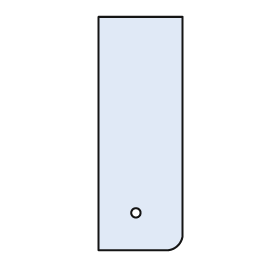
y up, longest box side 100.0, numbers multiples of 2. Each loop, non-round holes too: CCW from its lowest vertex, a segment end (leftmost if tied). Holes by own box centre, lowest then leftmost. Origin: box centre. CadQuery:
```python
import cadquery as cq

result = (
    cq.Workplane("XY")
    .moveTo(-18.0, -50.0)
    .lineTo(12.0, -50.0)
    .threePointArc((16.0, -48.0), (18.0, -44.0))
    .lineTo(18.0, 50.0)
    .lineTo(-18.0, 50.0)
    .close()
    .moveTo(-2.0, -34.0)
    .circle(2.0)
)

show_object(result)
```